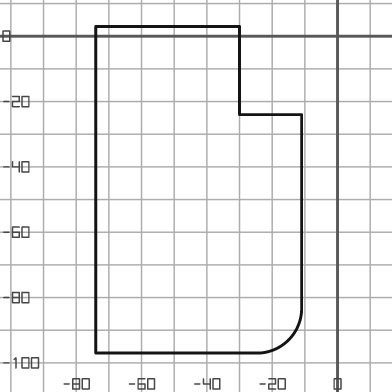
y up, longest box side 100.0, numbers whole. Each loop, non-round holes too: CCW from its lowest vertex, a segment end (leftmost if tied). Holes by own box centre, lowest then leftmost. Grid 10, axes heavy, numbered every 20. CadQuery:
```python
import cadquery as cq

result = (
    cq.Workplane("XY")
    .moveTo(-74.0, -97.0)
    .lineTo(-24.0, -97.0)
    .threePointArc((-15.0, -93.0), (-11.0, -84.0))
    .lineTo(-11.0, -24.0)
    .lineTo(-30.0, -24.0)
    .lineTo(-30.0, 3.0)
    .lineTo(-74.0, 3.0)
    .close()
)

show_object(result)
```